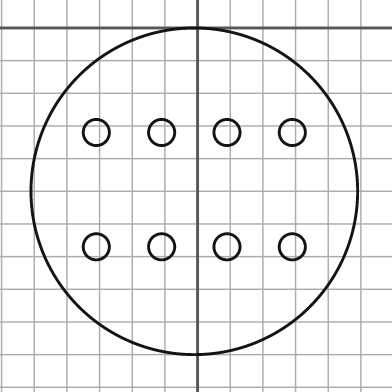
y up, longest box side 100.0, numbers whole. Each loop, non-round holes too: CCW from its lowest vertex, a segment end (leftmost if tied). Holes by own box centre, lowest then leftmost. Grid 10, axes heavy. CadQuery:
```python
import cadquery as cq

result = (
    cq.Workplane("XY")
    .moveTo(-1.0, -50.0)
    .circle(50.0)
    .moveTo(-31.0, -67.0)
    .circle(4.0)
    .moveTo(-11.0, -67.0)
    .circle(4.0)
    .moveTo(9.0, -67.0)
    .circle(4.0)
    .moveTo(29.0, -67.0)
    .circle(4.0)
    .moveTo(-31.0, -32.0)
    .circle(4.0)
    .moveTo(-11.0, -32.0)
    .circle(4.0)
    .moveTo(9.0, -32.0)
    .circle(4.0)
    .moveTo(29.0, -32.0)
    .circle(4.0)
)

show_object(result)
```